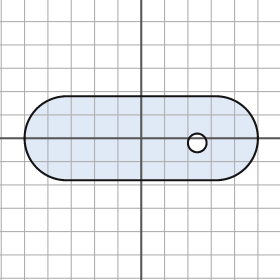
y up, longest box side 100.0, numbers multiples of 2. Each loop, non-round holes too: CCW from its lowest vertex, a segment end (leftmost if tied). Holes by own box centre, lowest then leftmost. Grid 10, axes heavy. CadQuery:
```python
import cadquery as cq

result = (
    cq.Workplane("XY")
    .moveTo(-32.0, -18.0)
    .lineTo(32.0, -18.0)
    .threePointArc((50.0, 0.0), (32.0, 18.0))
    .lineTo(-32.0, 18.0)
    .threePointArc((-50.0, 0.0), (-32.0, -18.0))
    .close()
    .moveTo(24.0, -2.0)
    .circle(4.0)
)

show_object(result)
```